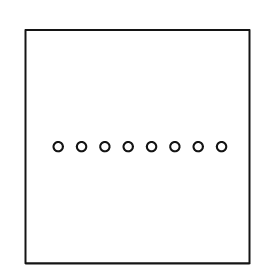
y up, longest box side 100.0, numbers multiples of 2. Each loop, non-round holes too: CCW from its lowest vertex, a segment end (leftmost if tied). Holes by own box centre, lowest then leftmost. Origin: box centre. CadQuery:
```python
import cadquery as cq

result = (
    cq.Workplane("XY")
    .moveTo(-48.0, -50.0)
    .lineTo(48.0, -50.0)
    .lineTo(48.0, 50.0)
    .lineTo(-48.0, 50.0)
    .close()
    .moveTo(-34.0, 0.0)
    .circle(2.0)
    .moveTo(-24.0, 0.0)
    .circle(2.0)
    .moveTo(-14.0, 0.0)
    .circle(2.0)
    .moveTo(-4.0, 0.0)
    .circle(2.0)
    .moveTo(6.0, 0.0)
    .circle(2.0)
    .moveTo(16.0, 0.0)
    .circle(2.0)
    .moveTo(26.0, 0.0)
    .circle(2.0)
    .moveTo(36.0, 0.0)
    .circle(2.0)
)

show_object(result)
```